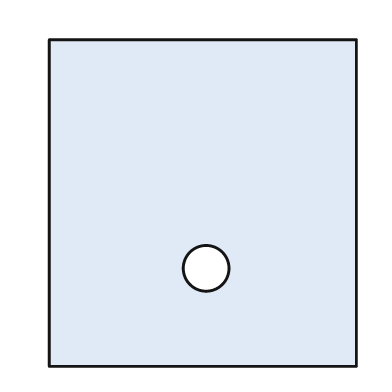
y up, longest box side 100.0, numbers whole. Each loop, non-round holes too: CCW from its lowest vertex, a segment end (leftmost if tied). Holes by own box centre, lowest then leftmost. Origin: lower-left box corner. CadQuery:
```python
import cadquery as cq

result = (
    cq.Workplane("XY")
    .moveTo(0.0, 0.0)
    .lineTo(94.0, 0.0)
    .lineTo(94.0, 100.0)
    .lineTo(0.0, 100.0)
    .close()
    .moveTo(48.0, 30.0)
    .circle(7.0)
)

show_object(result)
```